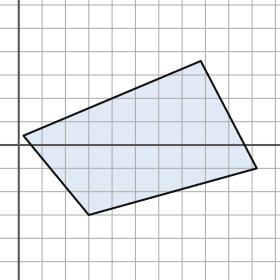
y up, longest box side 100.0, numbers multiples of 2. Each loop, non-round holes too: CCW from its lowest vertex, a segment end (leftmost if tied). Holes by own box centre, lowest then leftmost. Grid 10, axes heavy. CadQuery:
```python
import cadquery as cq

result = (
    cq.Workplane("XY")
    .moveTo(30.0, -30.0)
    .lineTo(102.0, -10.0)
    .lineTo(78.0, 36.0)
    .lineTo(2.0, 4.0)
    .close()
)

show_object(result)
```